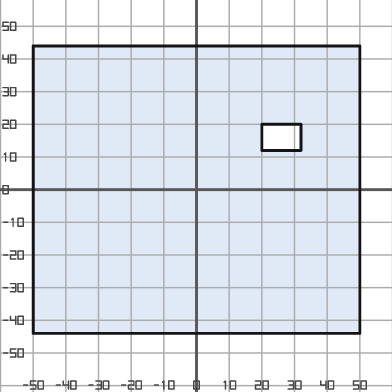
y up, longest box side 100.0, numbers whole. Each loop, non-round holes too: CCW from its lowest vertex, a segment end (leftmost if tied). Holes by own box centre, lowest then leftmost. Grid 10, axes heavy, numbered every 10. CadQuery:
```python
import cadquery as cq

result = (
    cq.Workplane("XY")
    .moveTo(-50.0, -44.0)
    .lineTo(50.0, -44.0)
    .lineTo(50.0, 44.0)
    .lineTo(-50.0, 44.0)
    .close()
    .moveTo(20.0, 12.0)
    .lineTo(32.0, 12.0)
    .lineTo(32.0, 20.0)
    .lineTo(20.0, 20.0)
    .close()
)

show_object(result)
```